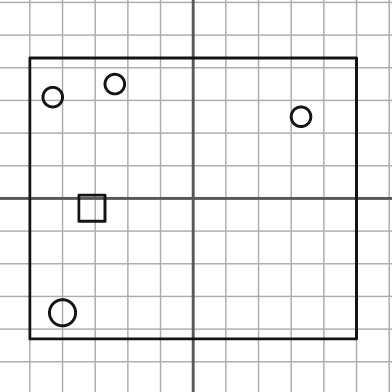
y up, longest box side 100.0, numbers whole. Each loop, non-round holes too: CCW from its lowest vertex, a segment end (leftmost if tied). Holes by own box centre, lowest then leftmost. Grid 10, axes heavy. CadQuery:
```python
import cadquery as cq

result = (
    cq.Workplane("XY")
    .moveTo(-50.0, -43.0)
    .lineTo(50.0, -43.0)
    .lineTo(50.0, 43.0)
    .lineTo(-50.0, 43.0)
    .close()
    .moveTo(-40.0, -35.0)
    .circle(4.0)
    .moveTo(-35.0, -7.0)
    .lineTo(-27.0, -7.0)
    .lineTo(-27.0, 1.0)
    .lineTo(-35.0, 1.0)
    .close()
    .moveTo(33.0, 25.0)
    .circle(3.0)
    .moveTo(-43.0, 31.0)
    .circle(3.0)
    .moveTo(-24.0, 35.0)
    .circle(3.0)
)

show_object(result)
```